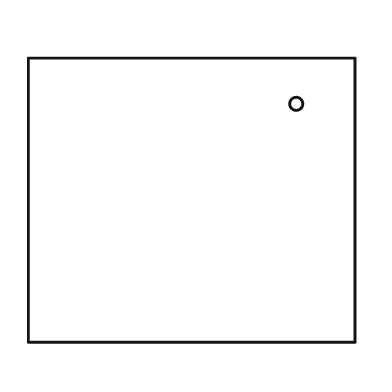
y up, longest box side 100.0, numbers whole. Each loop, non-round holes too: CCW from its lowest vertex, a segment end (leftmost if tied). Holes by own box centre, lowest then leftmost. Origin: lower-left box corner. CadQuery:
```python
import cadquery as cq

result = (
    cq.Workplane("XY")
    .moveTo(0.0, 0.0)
    .lineTo(100.0, 0.0)
    .lineTo(100.0, 87.0)
    .lineTo(0.0, 87.0)
    .close()
    .moveTo(82.0, 73.0)
    .circle(2.0)
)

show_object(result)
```